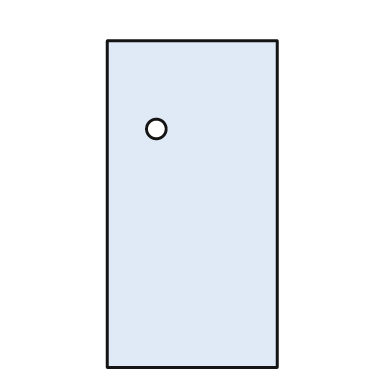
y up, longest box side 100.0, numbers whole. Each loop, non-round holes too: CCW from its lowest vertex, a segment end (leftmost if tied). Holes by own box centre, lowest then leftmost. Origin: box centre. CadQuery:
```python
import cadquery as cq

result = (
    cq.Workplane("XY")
    .moveTo(-26.0, -50.0)
    .lineTo(26.0, -50.0)
    .lineTo(26.0, 50.0)
    .lineTo(-26.0, 50.0)
    .close()
    .moveTo(-11.0, 23.0)
    .circle(3.0)
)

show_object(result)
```